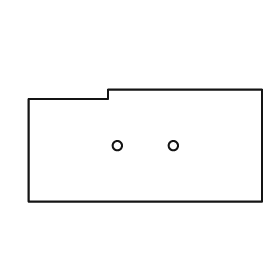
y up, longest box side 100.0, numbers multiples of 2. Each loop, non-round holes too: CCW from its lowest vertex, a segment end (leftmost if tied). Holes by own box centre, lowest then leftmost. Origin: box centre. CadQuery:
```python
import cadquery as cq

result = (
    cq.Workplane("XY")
    .moveTo(-50.0, -24.0)
    .lineTo(50.0, -24.0)
    .lineTo(50.0, 24.0)
    .lineTo(-16.0, 24.0)
    .lineTo(-16.0, 20.0)
    .lineTo(-50.0, 20.0)
    .close()
    .moveTo(-12.0, 0.0)
    .circle(2.0)
    .moveTo(12.0, 0.0)
    .circle(2.0)
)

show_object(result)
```